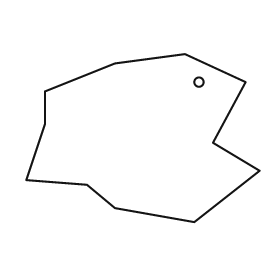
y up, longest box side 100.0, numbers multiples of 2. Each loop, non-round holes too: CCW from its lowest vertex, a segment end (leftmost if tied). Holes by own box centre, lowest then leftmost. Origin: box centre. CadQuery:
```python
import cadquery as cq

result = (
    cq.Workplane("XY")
    .moveTo(22.0, -36.0)
    .lineTo(50.0, -14.0)
    .lineTo(30.0, -2.0)
    .lineTo(44.0, 24.0)
    .lineTo(18.0, 36.0)
    .lineTo(-12.0, 32.0)
    .lineTo(-42.0, 20.0)
    .lineTo(-42.0, 6.0)
    .lineTo(-50.0, -18.0)
    .lineTo(-24.0, -20.0)
    .lineTo(-12.0, -30.0)
    .close()
    .moveTo(24.0, 24.0)
    .circle(2.0)
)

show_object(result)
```